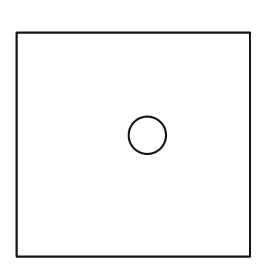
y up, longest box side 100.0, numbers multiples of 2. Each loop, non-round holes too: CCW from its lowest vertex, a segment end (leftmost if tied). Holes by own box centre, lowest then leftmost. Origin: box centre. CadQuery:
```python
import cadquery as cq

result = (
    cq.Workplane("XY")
    .moveTo(-50.0, -48.0)
    .lineTo(50.0, -48.0)
    .lineTo(50.0, 48.0)
    .lineTo(-50.0, 48.0)
    .close()
    .moveTo(6.0, 4.0)
    .circle(8.0)
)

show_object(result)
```